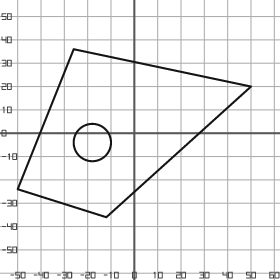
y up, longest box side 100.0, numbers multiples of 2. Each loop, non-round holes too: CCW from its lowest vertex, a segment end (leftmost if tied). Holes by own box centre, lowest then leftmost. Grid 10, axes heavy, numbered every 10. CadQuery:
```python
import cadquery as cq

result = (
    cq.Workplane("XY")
    .moveTo(-12.0, -36.0)
    .lineTo(50.0, 20.0)
    .lineTo(-26.0, 36.0)
    .lineTo(-50.0, -24.0)
    .close()
    .moveTo(-18.0, -4.0)
    .circle(8.0)
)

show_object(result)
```